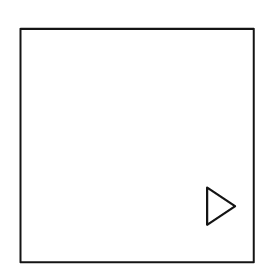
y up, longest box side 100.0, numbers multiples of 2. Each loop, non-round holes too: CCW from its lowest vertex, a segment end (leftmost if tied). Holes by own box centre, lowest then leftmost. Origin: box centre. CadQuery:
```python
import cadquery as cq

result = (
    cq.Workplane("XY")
    .moveTo(-50.0, -50.0)
    .lineTo(50.0, -50.0)
    .lineTo(50.0, 50.0)
    .lineTo(-50.0, 50.0)
    .close()
    .moveTo(30.0, -34.0)
    .lineTo(42.0, -26.0)
    .lineTo(30.0, -18.0)
    .close()
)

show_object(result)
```